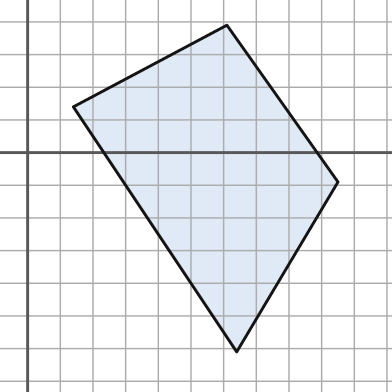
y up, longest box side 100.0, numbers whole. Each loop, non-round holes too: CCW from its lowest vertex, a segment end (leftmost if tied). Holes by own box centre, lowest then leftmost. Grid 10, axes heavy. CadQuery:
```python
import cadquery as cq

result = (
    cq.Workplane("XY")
    .moveTo(64.0, -61.0)
    .lineTo(95.0, -9.0)
    .lineTo(61.0, 39.0)
    .lineTo(14.0, 14.0)
    .close()
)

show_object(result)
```